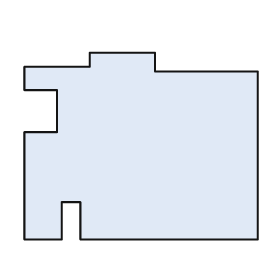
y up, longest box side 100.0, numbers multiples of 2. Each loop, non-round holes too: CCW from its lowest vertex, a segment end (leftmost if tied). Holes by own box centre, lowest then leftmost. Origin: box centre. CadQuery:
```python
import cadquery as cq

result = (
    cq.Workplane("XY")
    .moveTo(-50.0, -40.0)
    .lineTo(-34.0, -40.0)
    .lineTo(-34.0, -24.0)
    .lineTo(-26.0, -24.0)
    .lineTo(-26.0, -40.0)
    .lineTo(50.0, -40.0)
    .lineTo(50.0, 32.0)
    .lineTo(6.0, 32.0)
    .lineTo(6.0, 40.0)
    .lineTo(-22.0, 40.0)
    .lineTo(-22.0, 34.0)
    .lineTo(-50.0, 34.0)
    .lineTo(-50.0, 24.0)
    .lineTo(-36.0, 24.0)
    .lineTo(-36.0, 6.0)
    .lineTo(-50.0, 6.0)
    .close()
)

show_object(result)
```